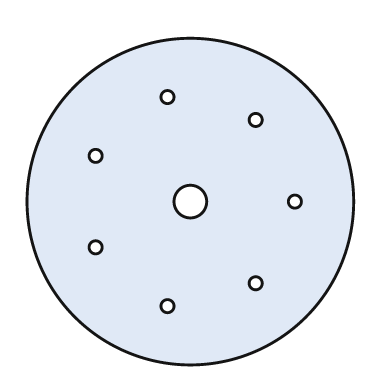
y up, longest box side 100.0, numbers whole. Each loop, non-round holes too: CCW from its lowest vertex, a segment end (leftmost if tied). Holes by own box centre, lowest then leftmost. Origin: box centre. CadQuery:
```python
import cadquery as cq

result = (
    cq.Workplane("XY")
    .moveTo(0.0, 0.0)
    .circle(50.0)
    .moveTo(-7.0, -32.0)
    .circle(2.0)
    .moveTo(20.0, -25.0)
    .circle(2.0)
    .moveTo(-29.0, -14.0)
    .circle(2.0)
    .moveTo(0.0, 0.0)
    .circle(5.0)
    .moveTo(32.0, 0.0)
    .circle(2.0)
    .moveTo(-29.0, 14.0)
    .circle(2.0)
    .moveTo(20.0, 25.0)
    .circle(2.0)
    .moveTo(-7.0, 32.0)
    .circle(2.0)
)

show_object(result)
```